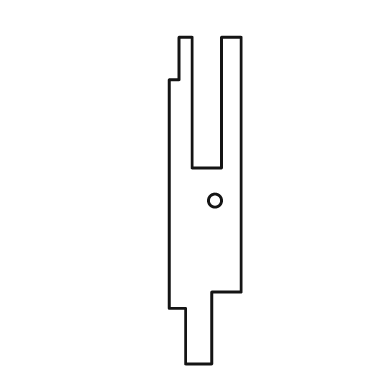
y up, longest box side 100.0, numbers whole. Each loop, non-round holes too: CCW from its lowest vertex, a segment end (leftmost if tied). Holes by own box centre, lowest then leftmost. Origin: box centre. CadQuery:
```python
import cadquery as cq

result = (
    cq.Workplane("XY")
    .moveTo(-6.0, -50.0)
    .lineTo(2.0, -50.0)
    .lineTo(2.0, -28.0)
    .lineTo(11.0, -28.0)
    .lineTo(11.0, 50.0)
    .lineTo(5.0, 50.0)
    .lineTo(5.0, 10.0)
    .lineTo(-4.0, 10.0)
    .lineTo(-4.0, 50.0)
    .lineTo(-8.0, 50.0)
    .lineTo(-8.0, 37.0)
    .lineTo(-11.0, 37.0)
    .lineTo(-11.0, -33.0)
    .lineTo(-6.0, -33.0)
    .close()
    .moveTo(3.0, 0.0)
    .circle(2.0)
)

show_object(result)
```